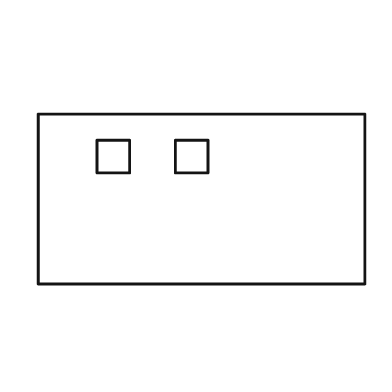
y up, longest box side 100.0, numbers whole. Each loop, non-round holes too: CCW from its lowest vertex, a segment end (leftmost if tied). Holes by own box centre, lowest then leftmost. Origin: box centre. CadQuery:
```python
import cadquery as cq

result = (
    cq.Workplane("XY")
    .moveTo(-50.0, -26.0)
    .lineTo(50.0, -26.0)
    .lineTo(50.0, 26.0)
    .lineTo(-50.0, 26.0)
    .close()
    .moveTo(-32.0, 8.0)
    .lineTo(-22.0, 8.0)
    .lineTo(-22.0, 18.0)
    .lineTo(-32.0, 18.0)
    .close()
    .moveTo(-8.0, 8.0)
    .lineTo(2.0, 8.0)
    .lineTo(2.0, 18.0)
    .lineTo(-8.0, 18.0)
    .close()
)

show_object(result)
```